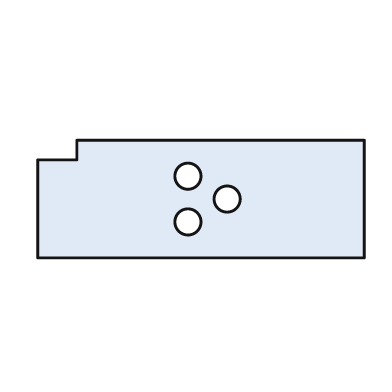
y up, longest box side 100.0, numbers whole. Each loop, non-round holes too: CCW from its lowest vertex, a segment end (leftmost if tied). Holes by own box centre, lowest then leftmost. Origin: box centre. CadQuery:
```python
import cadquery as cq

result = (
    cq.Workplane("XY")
    .moveTo(-50.0, -18.0)
    .lineTo(50.0, -18.0)
    .lineTo(50.0, 18.0)
    .lineTo(-38.0, 18.0)
    .lineTo(-38.0, 12.0)
    .lineTo(-50.0, 12.0)
    .close()
    .moveTo(-4.0, -7.0)
    .circle(4.0)
    .moveTo(8.0, 0.0)
    .circle(4.0)
    .moveTo(-4.0, 7.0)
    .circle(4.0)
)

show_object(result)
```